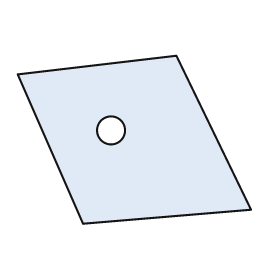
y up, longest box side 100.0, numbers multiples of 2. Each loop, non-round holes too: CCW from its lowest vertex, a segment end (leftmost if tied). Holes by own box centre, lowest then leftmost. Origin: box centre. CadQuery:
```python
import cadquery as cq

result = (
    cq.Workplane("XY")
    .moveTo(-22.0, -36.0)
    .lineTo(50.0, -30.0)
    .lineTo(18.0, 36.0)
    .lineTo(-50.0, 28.0)
    .close()
    .moveTo(-10.0, 4.0)
    .circle(6.0)
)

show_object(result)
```